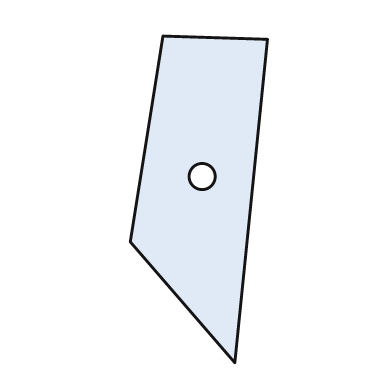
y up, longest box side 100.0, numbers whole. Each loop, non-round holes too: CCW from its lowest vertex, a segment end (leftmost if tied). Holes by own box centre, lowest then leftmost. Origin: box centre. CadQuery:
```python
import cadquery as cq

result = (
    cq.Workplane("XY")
    .moveTo(11.0, -50.0)
    .lineTo(21.0, 49.0)
    .lineTo(-11.0, 50.0)
    .lineTo(-21.0, -13.0)
    .close()
    .moveTo(1.0, 7.0)
    .circle(4.0)
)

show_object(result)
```